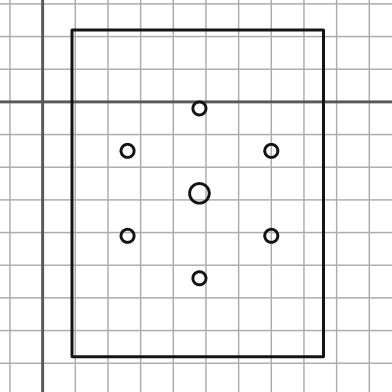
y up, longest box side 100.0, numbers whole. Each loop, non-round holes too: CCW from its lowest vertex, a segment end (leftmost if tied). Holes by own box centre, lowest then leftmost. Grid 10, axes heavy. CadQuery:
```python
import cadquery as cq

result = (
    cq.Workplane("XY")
    .moveTo(9.0, -78.0)
    .lineTo(86.0, -78.0)
    .lineTo(86.0, 22.0)
    .lineTo(9.0, 22.0)
    .close()
    .moveTo(48.0, -54.0)
    .circle(2.0)
    .moveTo(26.0, -41.0)
    .circle(2.0)
    .moveTo(70.0, -41.0)
    .circle(2.0)
    .moveTo(48.0, -28.0)
    .circle(3.0)
    .moveTo(26.0, -15.0)
    .circle(2.0)
    .moveTo(70.0, -15.0)
    .circle(2.0)
    .moveTo(48.0, -2.0)
    .circle(2.0)
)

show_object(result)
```